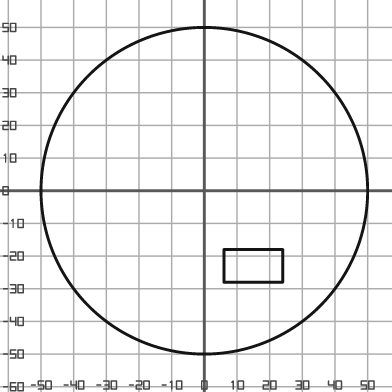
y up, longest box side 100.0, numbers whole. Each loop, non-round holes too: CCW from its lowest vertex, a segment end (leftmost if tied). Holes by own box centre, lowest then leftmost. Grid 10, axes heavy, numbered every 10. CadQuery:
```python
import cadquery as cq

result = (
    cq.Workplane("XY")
    .moveTo(0.0, 0.0)
    .circle(50.0)
    .moveTo(6.0, -28.0)
    .lineTo(24.0, -28.0)
    .lineTo(24.0, -18.0)
    .lineTo(6.0, -18.0)
    .close()
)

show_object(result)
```